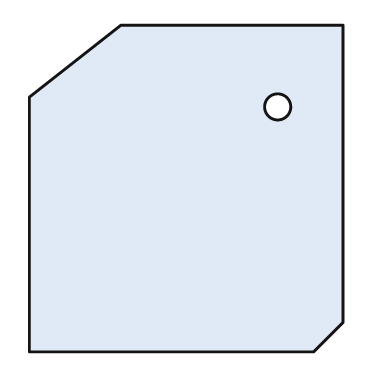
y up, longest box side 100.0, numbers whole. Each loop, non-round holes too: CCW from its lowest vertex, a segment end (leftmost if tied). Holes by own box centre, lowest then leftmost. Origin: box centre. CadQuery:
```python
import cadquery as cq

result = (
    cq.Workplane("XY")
    .moveTo(-48.0, -50.0)
    .lineTo(39.0, -50.0)
    .lineTo(48.0, -41.0)
    .lineTo(48.0, 50.0)
    .lineTo(-20.0, 50.0)
    .lineTo(-48.0, 28.0)
    .close()
    .moveTo(28.0, 25.0)
    .circle(4.0)
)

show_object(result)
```